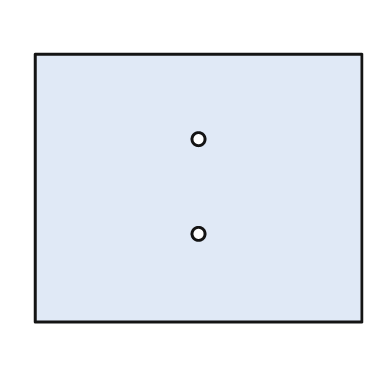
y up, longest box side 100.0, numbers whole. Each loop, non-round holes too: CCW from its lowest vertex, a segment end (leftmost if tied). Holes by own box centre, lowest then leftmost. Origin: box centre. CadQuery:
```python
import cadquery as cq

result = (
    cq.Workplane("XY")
    .moveTo(-50.0, -41.0)
    .lineTo(50.0, -41.0)
    .lineTo(50.0, 41.0)
    .lineTo(-50.0, 41.0)
    .close()
    .moveTo(0.0, -14.0)
    .circle(2.0)
    .moveTo(0.0, 15.0)
    .circle(2.0)
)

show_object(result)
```